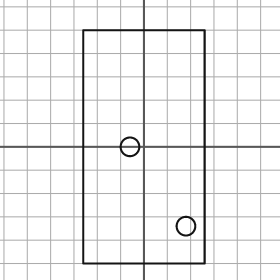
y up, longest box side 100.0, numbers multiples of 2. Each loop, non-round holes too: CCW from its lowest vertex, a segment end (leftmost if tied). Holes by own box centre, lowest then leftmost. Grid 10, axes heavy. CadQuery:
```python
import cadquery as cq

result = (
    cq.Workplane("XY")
    .moveTo(-26.0, -50.0)
    .lineTo(26.0, -50.0)
    .lineTo(26.0, 50.0)
    .lineTo(-26.0, 50.0)
    .close()
    .moveTo(18.0, -34.0)
    .circle(4.0)
    .moveTo(-6.0, 0.0)
    .circle(4.0)
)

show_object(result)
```